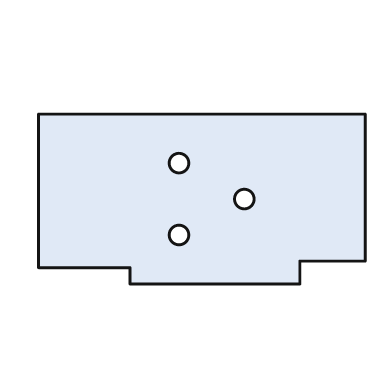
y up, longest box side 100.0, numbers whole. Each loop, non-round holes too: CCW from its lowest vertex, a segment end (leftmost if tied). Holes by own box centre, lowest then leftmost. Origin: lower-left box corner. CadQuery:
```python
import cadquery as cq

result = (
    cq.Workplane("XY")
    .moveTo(28.0, 0.0)
    .lineTo(80.0, 0.0)
    .lineTo(80.0, 7.0)
    .lineTo(100.0, 7.0)
    .lineTo(100.0, 52.0)
    .lineTo(0.0, 52.0)
    .lineTo(0.0, 5.0)
    .lineTo(28.0, 5.0)
    .close()
    .moveTo(43.0, 15.0)
    .circle(3.0)
    .moveTo(63.0, 26.0)
    .circle(3.0)
    .moveTo(43.0, 37.0)
    .circle(3.0)
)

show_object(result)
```